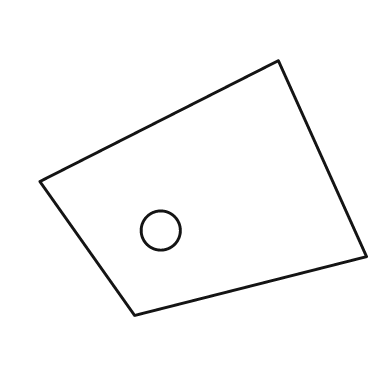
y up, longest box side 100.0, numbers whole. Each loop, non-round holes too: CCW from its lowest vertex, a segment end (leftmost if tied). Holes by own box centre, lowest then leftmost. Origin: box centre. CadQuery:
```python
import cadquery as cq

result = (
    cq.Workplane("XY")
    .moveTo(-21.0, -39.0)
    .lineTo(50.0, -21.0)
    .lineTo(23.0, 39.0)
    .lineTo(-50.0, 2.0)
    .close()
    .moveTo(-13.0, -13.0)
    .circle(6.0)
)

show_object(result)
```